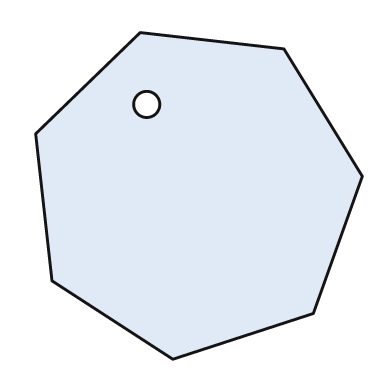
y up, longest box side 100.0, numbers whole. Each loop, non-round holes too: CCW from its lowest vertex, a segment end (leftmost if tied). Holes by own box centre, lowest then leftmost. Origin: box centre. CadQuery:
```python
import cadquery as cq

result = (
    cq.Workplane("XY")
    .moveTo(-8.0, -50.0)
    .lineTo(35.0, -36.0)
    .lineTo(50.0, 6.0)
    .lineTo(26.0, 45.0)
    .lineTo(-18.0, 50.0)
    .lineTo(-50.0, 19.0)
    .lineTo(-45.0, -26.0)
    .close()
    .moveTo(-16.0, 28.0)
    .circle(4.0)
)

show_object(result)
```